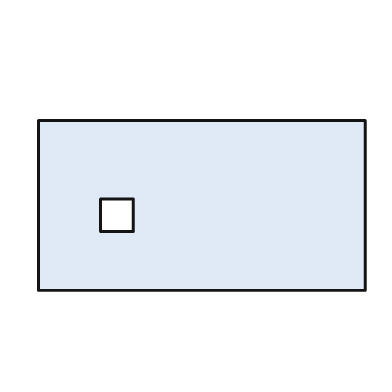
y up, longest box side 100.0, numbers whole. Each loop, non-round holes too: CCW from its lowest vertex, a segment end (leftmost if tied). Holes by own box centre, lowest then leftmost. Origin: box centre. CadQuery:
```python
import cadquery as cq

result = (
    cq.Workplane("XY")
    .moveTo(-50.0, -26.0)
    .lineTo(50.0, -26.0)
    .lineTo(50.0, 26.0)
    .lineTo(-50.0, 26.0)
    .close()
    .moveTo(-31.0, -8.0)
    .lineTo(-21.0, -8.0)
    .lineTo(-21.0, 2.0)
    .lineTo(-31.0, 2.0)
    .close()
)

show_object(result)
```